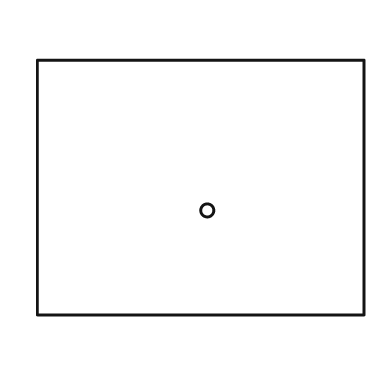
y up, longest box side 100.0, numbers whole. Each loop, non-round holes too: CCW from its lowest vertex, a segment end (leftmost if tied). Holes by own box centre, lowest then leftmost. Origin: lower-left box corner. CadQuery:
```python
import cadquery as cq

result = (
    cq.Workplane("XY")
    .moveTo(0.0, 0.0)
    .lineTo(100.0, 0.0)
    .lineTo(100.0, 78.0)
    .lineTo(0.0, 78.0)
    .close()
    .moveTo(52.0, 32.0)
    .circle(2.0)
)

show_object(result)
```